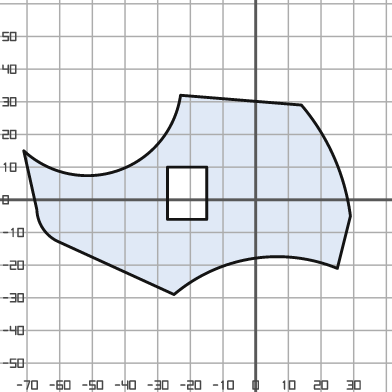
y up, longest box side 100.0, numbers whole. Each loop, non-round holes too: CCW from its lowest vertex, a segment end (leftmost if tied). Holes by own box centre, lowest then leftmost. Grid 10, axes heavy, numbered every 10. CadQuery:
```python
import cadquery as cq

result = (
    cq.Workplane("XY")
    .moveTo(-25.0, -29.0)
    .threePointArc((-1.0, -18.0), (25.0, -21.0))
    .lineTo(29.0, -5.0)
    .threePointArc((24.0, 13.0), (14.0, 29.0))
    .lineTo(-23.0, 32.0)
    .threePointArc((-42.0, 9.0), (-71.0, 15.0))
    .lineTo(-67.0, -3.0)
    .threePointArc((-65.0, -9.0), (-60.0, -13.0))
    .close()
    .moveTo(-27.0, -6.0)
    .lineTo(-15.0, -6.0)
    .lineTo(-15.0, 10.0)
    .lineTo(-27.0, 10.0)
    .close()
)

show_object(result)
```